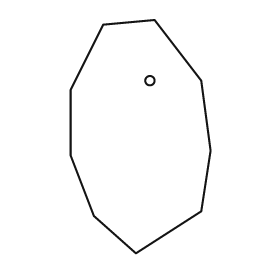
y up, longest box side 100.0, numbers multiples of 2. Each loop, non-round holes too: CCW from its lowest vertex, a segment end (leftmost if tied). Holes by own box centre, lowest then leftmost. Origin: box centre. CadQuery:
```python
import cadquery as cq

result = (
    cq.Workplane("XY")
    .moveTo(-2.0, -50.0)
    .lineTo(26.0, -32.0)
    .lineTo(30.0, -6.0)
    .lineTo(26.0, 24.0)
    .lineTo(6.0, 50.0)
    .lineTo(-16.0, 48.0)
    .lineTo(-30.0, 20.0)
    .lineTo(-30.0, -8.0)
    .lineTo(-20.0, -34.0)
    .close()
    .moveTo(4.0, 24.0)
    .circle(2.0)
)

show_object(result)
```